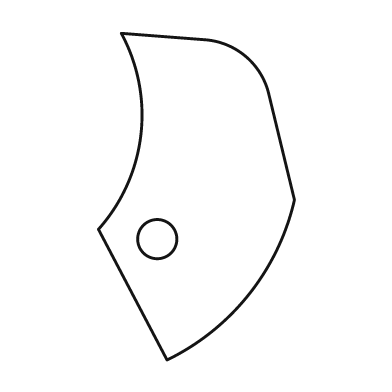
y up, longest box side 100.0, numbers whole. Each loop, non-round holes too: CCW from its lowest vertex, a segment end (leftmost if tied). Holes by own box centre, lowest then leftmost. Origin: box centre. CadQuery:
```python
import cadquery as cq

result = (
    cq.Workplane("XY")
    .moveTo(-9.0, -50.0)
    .threePointArc((16.0, -30.0), (30.0, -1.0))
    .lineTo(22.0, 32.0)
    .threePointArc((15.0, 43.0), (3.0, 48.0))
    .lineTo(-23.0, 50.0)
    .threePointArc((-17.0, 19.0), (-30.0, -10.0))
    .close()
    .moveTo(-12.0, -13.0)
    .circle(6.0)
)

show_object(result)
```